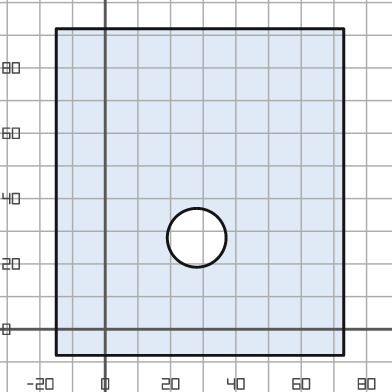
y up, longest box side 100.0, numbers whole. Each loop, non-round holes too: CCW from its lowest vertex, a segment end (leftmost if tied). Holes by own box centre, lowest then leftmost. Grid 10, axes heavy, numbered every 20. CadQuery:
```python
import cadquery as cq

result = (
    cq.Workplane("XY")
    .moveTo(-15.0, -8.0)
    .lineTo(73.0, -8.0)
    .lineTo(73.0, 92.0)
    .lineTo(-15.0, 92.0)
    .close()
    .moveTo(28.0, 28.0)
    .circle(9.0)
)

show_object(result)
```